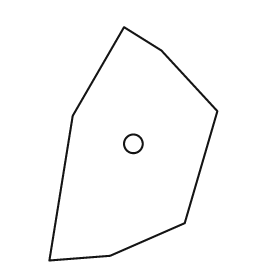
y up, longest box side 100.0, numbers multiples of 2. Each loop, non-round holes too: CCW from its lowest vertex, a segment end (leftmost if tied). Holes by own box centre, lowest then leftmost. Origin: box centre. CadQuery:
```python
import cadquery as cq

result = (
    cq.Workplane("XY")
    .moveTo(-36.0, -50.0)
    .lineTo(-10.0, -48.0)
    .lineTo(22.0, -34.0)
    .lineTo(36.0, 14.0)
    .lineTo(12.0, 40.0)
    .lineTo(-4.0, 50.0)
    .lineTo(-26.0, 12.0)
    .close()
    .moveTo(0.0, 0.0)
    .circle(4.0)
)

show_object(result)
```